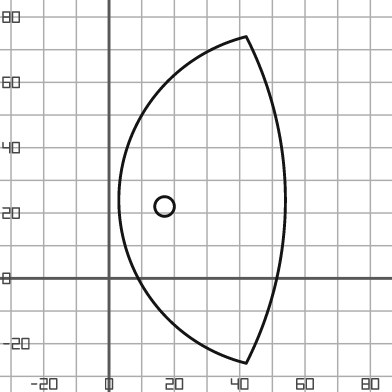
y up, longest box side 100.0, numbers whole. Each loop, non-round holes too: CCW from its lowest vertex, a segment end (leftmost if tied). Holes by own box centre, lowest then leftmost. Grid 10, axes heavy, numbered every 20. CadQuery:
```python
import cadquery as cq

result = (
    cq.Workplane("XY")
    .moveTo(42.0, -26.0)
    .threePointArc((54.0, 24.0), (42.0, 74.0))
    .threePointArc((3.0, 24.0), (42.0, -26.0))
    .close()
    .moveTo(17.0, 22.0)
    .circle(3.0)
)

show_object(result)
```